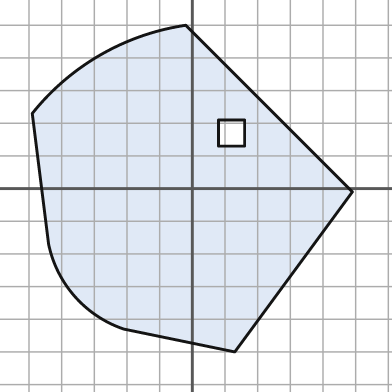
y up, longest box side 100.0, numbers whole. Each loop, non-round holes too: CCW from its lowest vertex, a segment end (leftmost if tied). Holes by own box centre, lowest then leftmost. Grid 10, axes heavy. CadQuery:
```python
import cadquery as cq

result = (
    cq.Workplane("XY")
    .moveTo(13.0, -50.0)
    .lineTo(49.0, -1.0)
    .lineTo(-2.0, 50.0)
    .threePointArc((-28.0, 41.0), (-49.0, 23.0))
    .lineTo(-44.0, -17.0)
    .threePointArc((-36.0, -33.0), (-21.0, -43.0))
    .close()
    .moveTo(8.0, 13.0)
    .lineTo(16.0, 13.0)
    .lineTo(16.0, 21.0)
    .lineTo(8.0, 21.0)
    .close()
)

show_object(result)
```